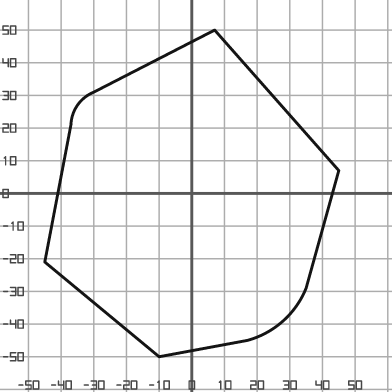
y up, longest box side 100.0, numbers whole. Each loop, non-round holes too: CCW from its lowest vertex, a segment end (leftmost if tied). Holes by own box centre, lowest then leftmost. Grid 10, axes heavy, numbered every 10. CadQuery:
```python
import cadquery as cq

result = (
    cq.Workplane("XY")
    .moveTo(-10.0, -50.0)
    .lineTo(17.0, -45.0)
    .threePointArc((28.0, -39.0), (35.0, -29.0))
    .lineTo(45.0, 7.0)
    .lineTo(7.0, 50.0)
    .lineTo(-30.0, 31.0)
    .threePointArc((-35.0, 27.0), (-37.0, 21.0))
    .lineTo(-45.0, -21.0)
    .close()
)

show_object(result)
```